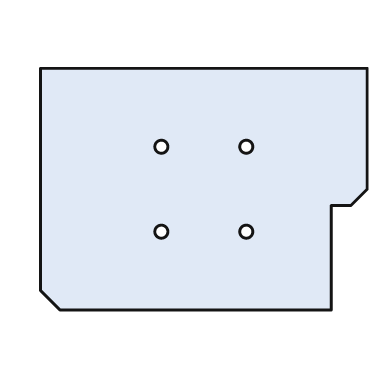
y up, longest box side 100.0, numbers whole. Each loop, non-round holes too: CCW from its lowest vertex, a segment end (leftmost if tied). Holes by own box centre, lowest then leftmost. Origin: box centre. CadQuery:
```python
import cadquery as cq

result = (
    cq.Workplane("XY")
    .moveTo(-44.0, -37.0)
    .lineTo(39.0, -37.0)
    .lineTo(39.0, -5.0)
    .lineTo(45.0, -5.0)
    .lineTo(50.0, 0.0)
    .lineTo(50.0, 37.0)
    .lineTo(-50.0, 37.0)
    .lineTo(-50.0, -31.0)
    .close()
    .moveTo(-13.0, -13.0)
    .circle(2.0)
    .moveTo(13.0, -13.0)
    .circle(2.0)
    .moveTo(-13.0, 13.0)
    .circle(2.0)
    .moveTo(13.0, 13.0)
    .circle(2.0)
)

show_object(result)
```